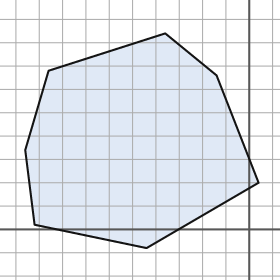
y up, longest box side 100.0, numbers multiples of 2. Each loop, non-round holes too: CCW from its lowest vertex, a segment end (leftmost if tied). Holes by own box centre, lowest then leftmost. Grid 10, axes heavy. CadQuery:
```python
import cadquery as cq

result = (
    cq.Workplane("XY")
    .moveTo(-44.0, -8.0)
    .lineTo(4.0, 20.0)
    .lineTo(-14.0, 66.0)
    .lineTo(-36.0, 84.0)
    .lineTo(-86.0, 68.0)
    .lineTo(-96.0, 34.0)
    .lineTo(-92.0, 2.0)
    .close()
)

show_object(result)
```